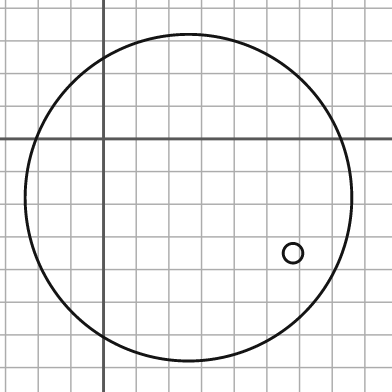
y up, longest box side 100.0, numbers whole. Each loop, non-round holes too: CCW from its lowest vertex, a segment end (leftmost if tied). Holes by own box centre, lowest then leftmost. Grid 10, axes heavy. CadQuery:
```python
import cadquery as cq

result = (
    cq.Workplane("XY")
    .moveTo(26.0, -18.0)
    .circle(50.0)
    .moveTo(58.0, -35.0)
    .circle(3.0)
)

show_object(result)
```